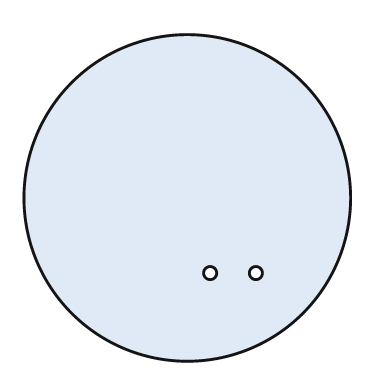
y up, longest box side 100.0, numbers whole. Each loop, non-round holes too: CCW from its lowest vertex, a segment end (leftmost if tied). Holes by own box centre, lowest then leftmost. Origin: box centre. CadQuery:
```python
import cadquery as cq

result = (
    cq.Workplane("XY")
    .moveTo(0.0, 0.0)
    .circle(50.0)
    .moveTo(7.0, -23.0)
    .circle(2.0)
    .moveTo(21.0, -23.0)
    .circle(2.0)
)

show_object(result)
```